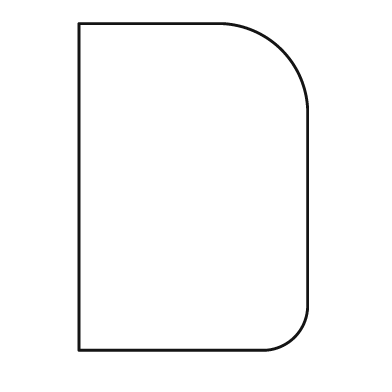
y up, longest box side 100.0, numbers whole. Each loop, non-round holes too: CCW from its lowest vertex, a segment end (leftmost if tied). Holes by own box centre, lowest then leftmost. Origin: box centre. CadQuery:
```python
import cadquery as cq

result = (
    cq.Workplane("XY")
    .moveTo(-35.0, -50.0)
    .lineTo(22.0, -50.0)
    .threePointArc((31.0, -46.0), (35.0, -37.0))
    .lineTo(35.0, 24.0)
    .threePointArc((27.0, 42.0), (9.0, 50.0))
    .lineTo(-35.0, 50.0)
    .close()
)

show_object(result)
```